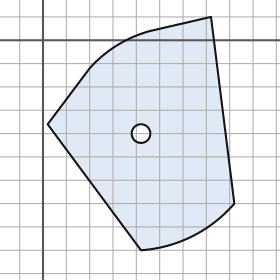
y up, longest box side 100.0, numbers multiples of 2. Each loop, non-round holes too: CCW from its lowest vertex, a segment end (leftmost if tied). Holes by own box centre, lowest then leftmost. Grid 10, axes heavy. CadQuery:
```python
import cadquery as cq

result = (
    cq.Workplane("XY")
    .moveTo(42.0, -90.0)
    .threePointArc((64.0, -84.0), (82.0, -70.0))
    .lineTo(72.0, 10.0)
    .lineTo(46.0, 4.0)
    .threePointArc((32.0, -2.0), (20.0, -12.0))
    .lineTo(2.0, -36.0)
    .close()
    .moveTo(42.0, -40.0)
    .circle(4.0)
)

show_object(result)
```